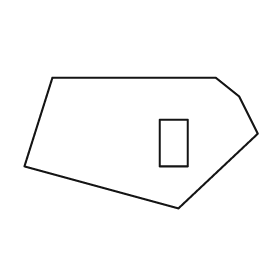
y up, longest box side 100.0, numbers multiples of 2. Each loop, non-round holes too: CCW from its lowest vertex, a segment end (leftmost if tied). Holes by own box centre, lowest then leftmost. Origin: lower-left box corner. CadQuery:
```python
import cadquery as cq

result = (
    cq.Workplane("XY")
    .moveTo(66.0, 0.0)
    .lineTo(100.0, 32.0)
    .lineTo(92.0, 48.0)
    .lineTo(82.0, 56.0)
    .lineTo(12.0, 56.0)
    .lineTo(0.0, 18.0)
    .close()
    .moveTo(58.0, 18.0)
    .lineTo(70.0, 18.0)
    .lineTo(70.0, 38.0)
    .lineTo(58.0, 38.0)
    .close()
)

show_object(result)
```